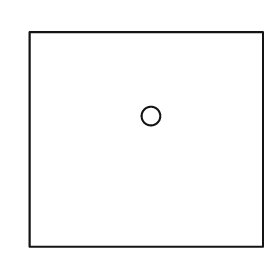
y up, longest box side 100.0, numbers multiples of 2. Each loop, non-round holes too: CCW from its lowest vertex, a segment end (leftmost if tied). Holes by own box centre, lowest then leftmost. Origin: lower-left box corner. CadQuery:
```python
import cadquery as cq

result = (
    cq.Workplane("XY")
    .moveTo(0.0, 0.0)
    .lineTo(100.0, 0.0)
    .lineTo(100.0, 92.0)
    .lineTo(0.0, 92.0)
    .close()
    .moveTo(52.0, 56.0)
    .circle(4.0)
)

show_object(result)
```